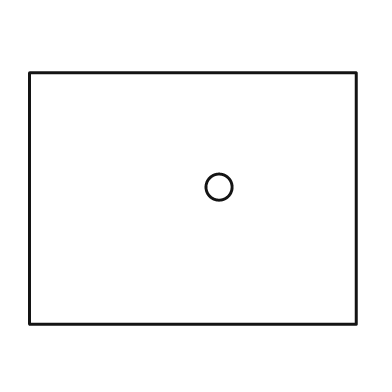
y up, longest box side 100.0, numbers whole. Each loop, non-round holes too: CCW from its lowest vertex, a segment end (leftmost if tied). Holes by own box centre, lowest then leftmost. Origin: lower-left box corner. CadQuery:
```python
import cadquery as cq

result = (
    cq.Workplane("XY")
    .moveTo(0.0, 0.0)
    .lineTo(100.0, 0.0)
    .lineTo(100.0, 77.0)
    .lineTo(0.0, 77.0)
    .close()
    .moveTo(58.0, 42.0)
    .circle(4.0)
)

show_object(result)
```